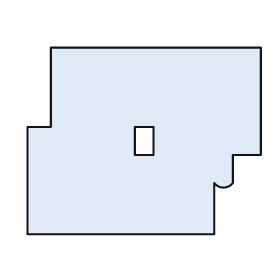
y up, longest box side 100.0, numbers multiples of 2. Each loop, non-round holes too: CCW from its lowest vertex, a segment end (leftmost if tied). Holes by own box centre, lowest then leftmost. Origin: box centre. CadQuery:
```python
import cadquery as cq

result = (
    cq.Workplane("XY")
    .moveTo(-50.0, -40.0)
    .lineTo(30.0, -40.0)
    .lineTo(30.0, -18.0)
    .threePointArc((34.0, -20.0), (38.0, -18.0))
    .lineTo(38.0, -6.0)
    .lineTo(50.0, -6.0)
    .lineTo(50.0, 40.0)
    .lineTo(-40.0, 40.0)
    .lineTo(-40.0, 6.0)
    .lineTo(-50.0, 6.0)
    .close()
    .moveTo(-4.0, -6.0)
    .lineTo(4.0, -6.0)
    .lineTo(4.0, 6.0)
    .lineTo(-4.0, 6.0)
    .close()
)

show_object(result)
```